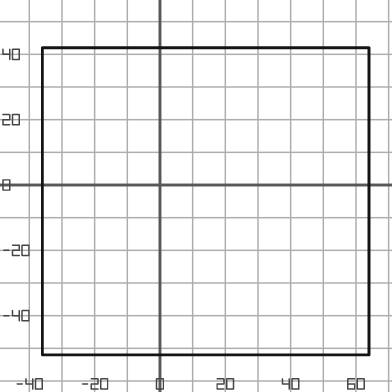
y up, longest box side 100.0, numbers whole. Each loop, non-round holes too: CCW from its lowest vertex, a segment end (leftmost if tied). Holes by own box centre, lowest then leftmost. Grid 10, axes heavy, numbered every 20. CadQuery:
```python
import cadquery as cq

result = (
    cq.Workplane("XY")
    .moveTo(-36.0, -52.0)
    .lineTo(64.0, -52.0)
    .lineTo(64.0, 42.0)
    .lineTo(-36.0, 42.0)
    .close()
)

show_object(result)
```